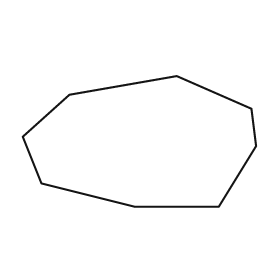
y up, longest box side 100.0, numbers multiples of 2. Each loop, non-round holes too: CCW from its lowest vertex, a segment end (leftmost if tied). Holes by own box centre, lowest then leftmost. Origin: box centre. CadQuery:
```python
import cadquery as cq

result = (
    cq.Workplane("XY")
    .moveTo(-2.0, -28.0)
    .lineTo(34.0, -28.0)
    .lineTo(50.0, -2.0)
    .lineTo(48.0, 14.0)
    .lineTo(16.0, 28.0)
    .lineTo(-30.0, 20.0)
    .lineTo(-50.0, 2.0)
    .lineTo(-42.0, -18.0)
    .close()
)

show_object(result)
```